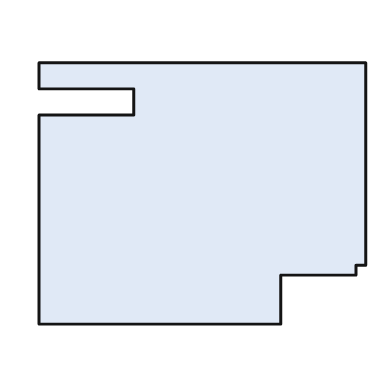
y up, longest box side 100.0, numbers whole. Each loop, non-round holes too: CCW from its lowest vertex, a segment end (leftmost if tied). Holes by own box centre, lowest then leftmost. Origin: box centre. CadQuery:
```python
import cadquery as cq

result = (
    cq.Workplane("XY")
    .moveTo(-50.0, -40.0)
    .lineTo(24.0, -40.0)
    .lineTo(24.0, -25.0)
    .lineTo(47.0, -25.0)
    .lineTo(47.0, -22.0)
    .lineTo(50.0, -22.0)
    .lineTo(50.0, 40.0)
    .lineTo(-50.0, 40.0)
    .lineTo(-50.0, 32.0)
    .lineTo(-21.0, 32.0)
    .lineTo(-21.0, 24.0)
    .lineTo(-50.0, 24.0)
    .close()
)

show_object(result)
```